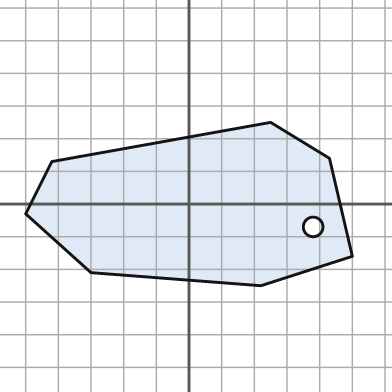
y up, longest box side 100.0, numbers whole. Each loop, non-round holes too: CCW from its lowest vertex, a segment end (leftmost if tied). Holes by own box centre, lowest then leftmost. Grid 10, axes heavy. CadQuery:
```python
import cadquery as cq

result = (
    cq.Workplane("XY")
    .moveTo(22.0, -25.0)
    .lineTo(50.0, -16.0)
    .lineTo(43.0, 14.0)
    .lineTo(25.0, 25.0)
    .lineTo(-42.0, 13.0)
    .lineTo(-50.0, -3.0)
    .lineTo(-30.0, -21.0)
    .close()
    .moveTo(38.0, -7.0)
    .circle(3.0)
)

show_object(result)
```